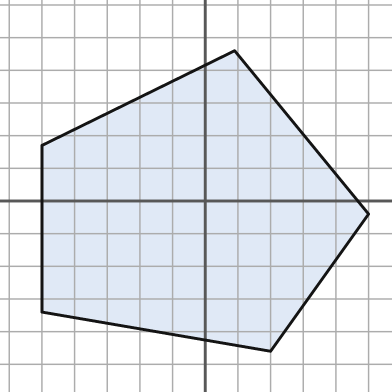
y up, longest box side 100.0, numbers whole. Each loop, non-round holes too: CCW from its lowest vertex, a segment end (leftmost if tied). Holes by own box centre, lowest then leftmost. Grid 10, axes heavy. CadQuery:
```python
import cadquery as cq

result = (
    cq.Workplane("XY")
    .moveTo(20.0, -46.0)
    .lineTo(50.0, -4.0)
    .lineTo(9.0, 46.0)
    .lineTo(-50.0, 17.0)
    .lineTo(-50.0, -34.0)
    .close()
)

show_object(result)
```